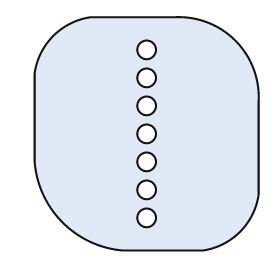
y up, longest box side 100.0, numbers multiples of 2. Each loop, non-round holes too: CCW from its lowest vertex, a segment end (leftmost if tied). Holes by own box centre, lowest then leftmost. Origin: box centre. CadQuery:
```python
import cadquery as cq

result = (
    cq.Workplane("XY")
    .moveTo(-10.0, -50.0)
    .lineTo(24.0, -50.0)
    .threePointArc((40.0, -42.0), (48.0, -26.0))
    .lineTo(48.0, 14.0)
    .threePointArc((38.0, 40.0), (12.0, 50.0))
    .lineTo(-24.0, 50.0)
    .threePointArc((-40.0, 42.0), (-48.0, 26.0))
    .lineTo(-48.0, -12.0)
    .threePointArc((-36.0, -38.0), (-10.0, -50.0))
    .close()
    .moveTo(0.0, -36.0)
    .circle(4.0)
    .moveTo(0.0, -24.0)
    .circle(4.0)
    .moveTo(0.0, -12.0)
    .circle(4.0)
    .moveTo(0.0, 0.0)
    .circle(4.0)
    .moveTo(0.0, 12.0)
    .circle(4.0)
    .moveTo(0.0, 24.0)
    .circle(4.0)
    .moveTo(0.0, 36.0)
    .circle(4.0)
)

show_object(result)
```